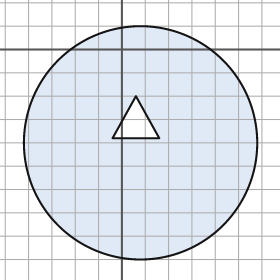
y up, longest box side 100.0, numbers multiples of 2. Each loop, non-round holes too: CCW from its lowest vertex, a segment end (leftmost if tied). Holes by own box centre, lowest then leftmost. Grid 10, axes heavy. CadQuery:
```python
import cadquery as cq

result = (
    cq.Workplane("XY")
    .moveTo(8.0, -40.0)
    .circle(50.0)
    .moveTo(-4.0, -38.0)
    .lineTo(16.0, -38.0)
    .lineTo(6.0, -20.0)
    .close()
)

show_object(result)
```